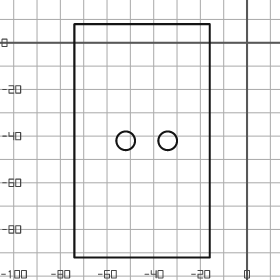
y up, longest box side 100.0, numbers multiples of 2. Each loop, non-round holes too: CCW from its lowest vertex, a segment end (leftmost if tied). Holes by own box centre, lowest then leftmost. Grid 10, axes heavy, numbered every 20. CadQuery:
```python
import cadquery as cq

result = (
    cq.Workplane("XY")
    .moveTo(-74.0, -92.0)
    .lineTo(-16.0, -92.0)
    .lineTo(-16.0, 8.0)
    .lineTo(-74.0, 8.0)
    .close()
    .moveTo(-52.0, -42.0)
    .circle(4.0)
    .moveTo(-34.0, -42.0)
    .circle(4.0)
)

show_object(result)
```